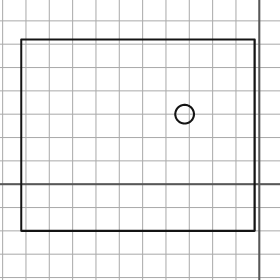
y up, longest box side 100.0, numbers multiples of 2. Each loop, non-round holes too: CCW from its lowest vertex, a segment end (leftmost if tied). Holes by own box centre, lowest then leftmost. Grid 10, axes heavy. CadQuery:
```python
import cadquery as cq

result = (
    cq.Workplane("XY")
    .moveTo(-102.0, -20.0)
    .lineTo(-2.0, -20.0)
    .lineTo(-2.0, 62.0)
    .lineTo(-102.0, 62.0)
    .close()
    .moveTo(-32.0, 30.0)
    .circle(4.0)
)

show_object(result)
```